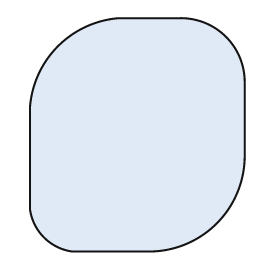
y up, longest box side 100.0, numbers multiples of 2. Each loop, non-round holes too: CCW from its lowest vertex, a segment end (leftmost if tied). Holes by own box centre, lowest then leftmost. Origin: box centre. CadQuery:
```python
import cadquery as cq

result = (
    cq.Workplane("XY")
    .moveTo(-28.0, -50.0)
    .lineTo(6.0, -50.0)
    .threePointArc((34.0, -38.0), (46.0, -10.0))
    .lineTo(46.0, 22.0)
    .threePointArc((38.0, 42.0), (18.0, 50.0))
    .lineTo(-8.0, 50.0)
    .threePointArc((-34.0, 38.0), (-46.0, 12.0))
    .lineTo(-46.0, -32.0)
    .threePointArc((-40.0, -44.0), (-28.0, -50.0))
    .close()
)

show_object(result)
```